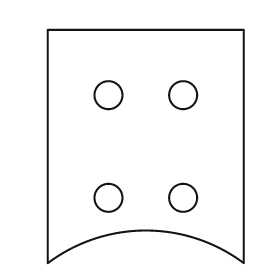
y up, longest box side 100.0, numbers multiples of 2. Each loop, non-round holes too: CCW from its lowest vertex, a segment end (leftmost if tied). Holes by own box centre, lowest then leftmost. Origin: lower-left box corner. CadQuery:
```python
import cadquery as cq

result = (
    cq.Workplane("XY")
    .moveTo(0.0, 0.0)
    .threePointArc((42.0, 14.0), (84.0, 0.0))
    .lineTo(84.0, 100.0)
    .lineTo(0.0, 100.0)
    .close()
    .moveTo(26.0, 28.0)
    .circle(6.0)
    .moveTo(58.0, 28.0)
    .circle(6.0)
    .moveTo(26.0, 72.0)
    .circle(6.0)
    .moveTo(58.0, 72.0)
    .circle(6.0)
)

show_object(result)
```